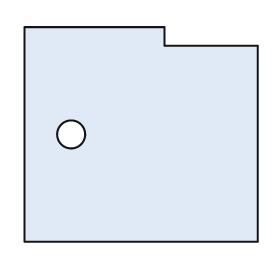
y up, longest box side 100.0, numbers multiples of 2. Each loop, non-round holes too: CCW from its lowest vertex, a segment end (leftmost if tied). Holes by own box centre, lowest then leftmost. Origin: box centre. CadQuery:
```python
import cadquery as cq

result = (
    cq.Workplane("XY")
    .moveTo(-50.0, -46.0)
    .lineTo(50.0, -46.0)
    .lineTo(50.0, 38.0)
    .lineTo(10.0, 38.0)
    .lineTo(10.0, 46.0)
    .lineTo(-50.0, 46.0)
    .close()
    .moveTo(-30.0, 0.0)
    .circle(6.0)
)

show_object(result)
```